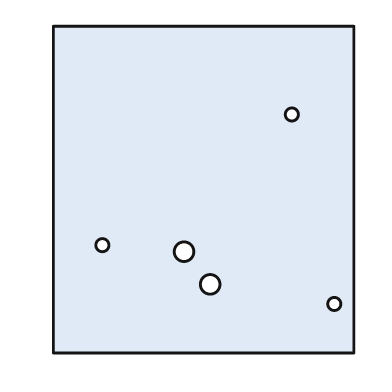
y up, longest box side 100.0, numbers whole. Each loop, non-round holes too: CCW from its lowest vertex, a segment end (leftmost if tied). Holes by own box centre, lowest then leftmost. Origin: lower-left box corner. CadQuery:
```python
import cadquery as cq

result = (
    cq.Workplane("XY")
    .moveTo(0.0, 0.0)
    .lineTo(92.0, 0.0)
    .lineTo(92.0, 100.0)
    .lineTo(0.0, 100.0)
    .close()
    .moveTo(86.0, 15.0)
    .circle(2.0)
    .moveTo(48.0, 21.0)
    .circle(3.0)
    .moveTo(40.0, 31.0)
    .circle(3.0)
    .moveTo(15.0, 33.0)
    .circle(2.0)
    .moveTo(73.0, 73.0)
    .circle(2.0)
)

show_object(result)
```